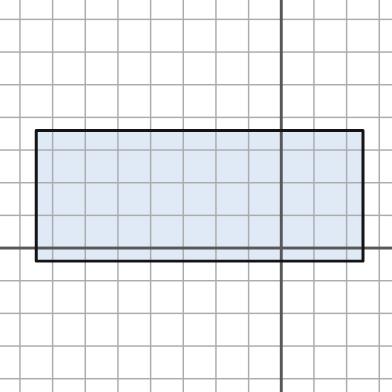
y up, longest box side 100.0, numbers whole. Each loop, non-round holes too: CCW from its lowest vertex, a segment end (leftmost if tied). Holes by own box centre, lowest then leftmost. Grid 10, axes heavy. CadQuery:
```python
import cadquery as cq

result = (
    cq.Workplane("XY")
    .moveTo(-75.0, -4.0)
    .lineTo(25.0, -4.0)
    .lineTo(25.0, 36.0)
    .lineTo(-75.0, 36.0)
    .close()
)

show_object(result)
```